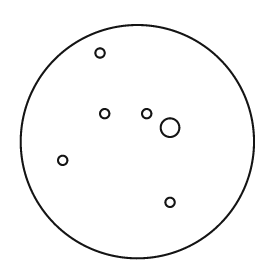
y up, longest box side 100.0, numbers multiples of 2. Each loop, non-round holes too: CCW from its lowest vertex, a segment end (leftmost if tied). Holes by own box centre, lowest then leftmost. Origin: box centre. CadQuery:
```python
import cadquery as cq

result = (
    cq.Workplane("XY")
    .moveTo(0.0, 0.0)
    .circle(50.0)
    .moveTo(14.0, -26.0)
    .circle(2.0)
    .moveTo(-32.0, -8.0)
    .circle(2.0)
    .moveTo(14.0, 6.0)
    .circle(4.0)
    .moveTo(-14.0, 12.0)
    .circle(2.0)
    .moveTo(4.0, 12.0)
    .circle(2.0)
    .moveTo(-16.0, 38.0)
    .circle(2.0)
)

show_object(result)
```